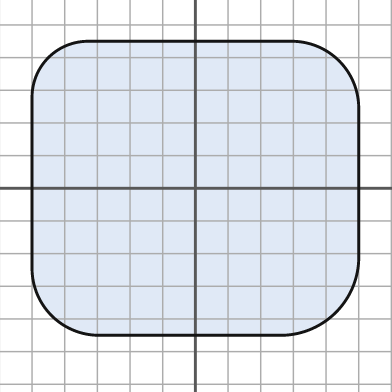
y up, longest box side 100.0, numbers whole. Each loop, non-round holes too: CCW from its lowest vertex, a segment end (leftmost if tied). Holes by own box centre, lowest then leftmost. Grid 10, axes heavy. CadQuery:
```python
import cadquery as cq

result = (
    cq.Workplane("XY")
    .moveTo(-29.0, -45.0)
    .lineTo(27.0, -45.0)
    .threePointArc((43.0, -38.0), (50.0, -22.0))
    .lineTo(50.0, 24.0)
    .threePointArc((44.0, 39.0), (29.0, 45.0))
    .lineTo(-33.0, 45.0)
    .threePointArc((-45.0, 40.0), (-50.0, 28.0))
    .lineTo(-50.0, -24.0)
    .threePointArc((-44.0, -39.0), (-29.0, -45.0))
    .close()
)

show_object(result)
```